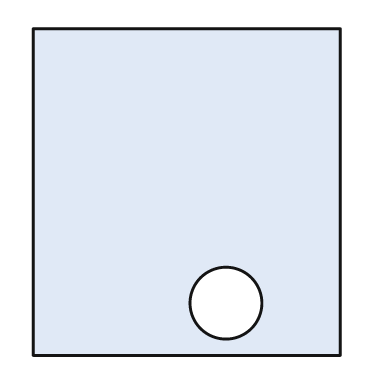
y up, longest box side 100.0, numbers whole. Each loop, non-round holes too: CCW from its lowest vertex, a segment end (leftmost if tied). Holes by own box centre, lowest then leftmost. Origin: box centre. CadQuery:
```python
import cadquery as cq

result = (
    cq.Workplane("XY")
    .moveTo(-47.0, -50.0)
    .lineTo(47.0, -50.0)
    .lineTo(47.0, 50.0)
    .lineTo(-47.0, 50.0)
    .close()
    .moveTo(12.0, -34.0)
    .circle(11.0)
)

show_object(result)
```